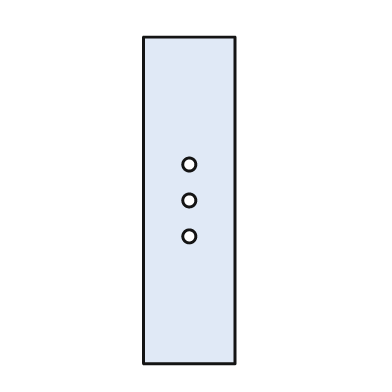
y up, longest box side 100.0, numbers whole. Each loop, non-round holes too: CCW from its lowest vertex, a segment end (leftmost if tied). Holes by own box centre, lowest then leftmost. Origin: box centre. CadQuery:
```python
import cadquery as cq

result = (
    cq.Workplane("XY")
    .moveTo(-14.0, -50.0)
    .lineTo(14.0, -50.0)
    .lineTo(14.0, 50.0)
    .lineTo(-14.0, 50.0)
    .close()
    .moveTo(0.0, -11.0)
    .circle(2.0)
    .moveTo(0.0, 0.0)
    .circle(2.0)
    .moveTo(0.0, 11.0)
    .circle(2.0)
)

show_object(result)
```